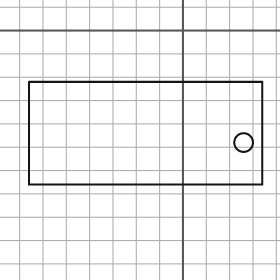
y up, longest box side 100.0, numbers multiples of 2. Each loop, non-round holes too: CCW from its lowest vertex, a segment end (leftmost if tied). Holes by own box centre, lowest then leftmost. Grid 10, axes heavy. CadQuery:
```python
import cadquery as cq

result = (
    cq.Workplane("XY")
    .moveTo(-66.0, -66.0)
    .lineTo(34.0, -66.0)
    .lineTo(34.0, -22.0)
    .lineTo(-66.0, -22.0)
    .close()
    .moveTo(26.0, -48.0)
    .circle(4.0)
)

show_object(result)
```